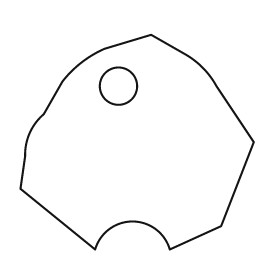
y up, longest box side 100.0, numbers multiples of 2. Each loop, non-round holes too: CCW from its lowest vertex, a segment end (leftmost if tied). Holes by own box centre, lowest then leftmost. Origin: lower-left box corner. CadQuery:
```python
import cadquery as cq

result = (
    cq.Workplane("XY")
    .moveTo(32.0, 0.0)
    .threePointArc((48.0, 12.0), (64.0, 0.0))
    .lineTo(86.0, 10.0)
    .lineTo(100.0, 46.0)
    .lineTo(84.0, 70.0)
    .threePointArc((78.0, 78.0), (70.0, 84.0))
    .lineTo(56.0, 92.0)
    .lineTo(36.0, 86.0)
    .threePointArc((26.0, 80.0), (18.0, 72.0))
    .lineTo(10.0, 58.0)
    .threePointArc((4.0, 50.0), (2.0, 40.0))
    .lineTo(0.0, 26.0)
    .close()
    .moveTo(42.0, 70.0)
    .circle(8.0)
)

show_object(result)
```